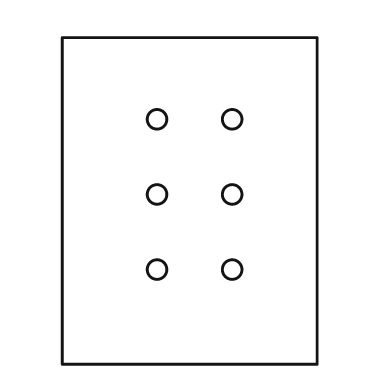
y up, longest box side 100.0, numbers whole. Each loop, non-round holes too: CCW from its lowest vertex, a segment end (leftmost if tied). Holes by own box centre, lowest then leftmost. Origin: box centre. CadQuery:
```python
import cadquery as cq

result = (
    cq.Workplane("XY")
    .moveTo(-39.0, -50.0)
    .lineTo(39.0, -50.0)
    .lineTo(39.0, 50.0)
    .lineTo(-39.0, 50.0)
    .close()
    .moveTo(-10.0, -21.0)
    .circle(3.0)
    .moveTo(13.0, -21.0)
    .circle(3.0)
    .moveTo(-10.0, 2.0)
    .circle(3.0)
    .moveTo(13.0, 2.0)
    .circle(3.0)
    .moveTo(-10.0, 25.0)
    .circle(3.0)
    .moveTo(13.0, 25.0)
    .circle(3.0)
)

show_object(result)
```